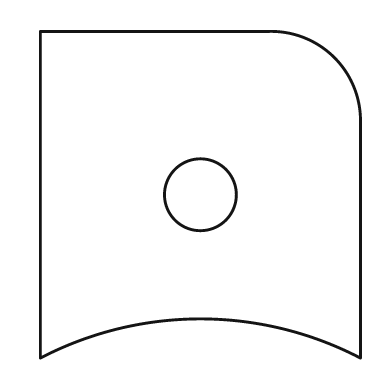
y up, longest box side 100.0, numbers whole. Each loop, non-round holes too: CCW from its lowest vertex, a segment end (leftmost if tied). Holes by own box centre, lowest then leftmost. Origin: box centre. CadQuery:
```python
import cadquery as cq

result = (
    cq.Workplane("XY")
    .moveTo(-49.0, -50.0)
    .threePointArc((0.0, -38.0), (49.0, -50.0))
    .lineTo(49.0, 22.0)
    .threePointArc((41.0, 42.0), (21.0, 50.0))
    .lineTo(-49.0, 50.0)
    .close()
    .moveTo(0.0, 0.0)
    .circle(11.0)
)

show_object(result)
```